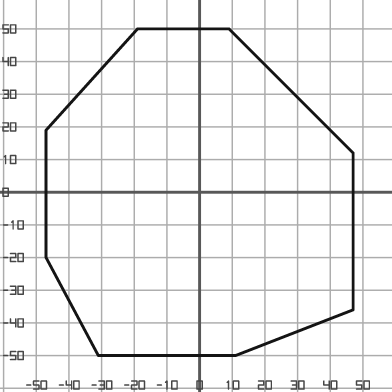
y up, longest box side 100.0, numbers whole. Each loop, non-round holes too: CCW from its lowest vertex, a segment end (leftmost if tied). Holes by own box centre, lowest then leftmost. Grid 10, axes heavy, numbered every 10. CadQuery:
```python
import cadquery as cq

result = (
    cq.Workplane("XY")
    .moveTo(-31.0, -50.0)
    .lineTo(11.0, -50.0)
    .lineTo(47.0, -36.0)
    .lineTo(47.0, 12.0)
    .lineTo(9.0, 50.0)
    .lineTo(-19.0, 50.0)
    .lineTo(-47.0, 19.0)
    .lineTo(-47.0, -20.0)
    .close()
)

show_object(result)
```